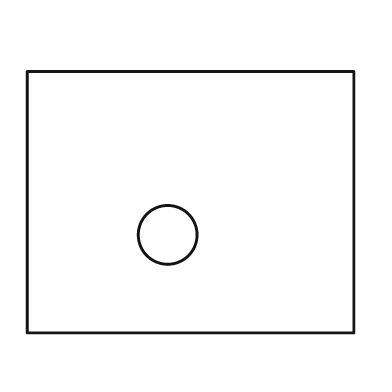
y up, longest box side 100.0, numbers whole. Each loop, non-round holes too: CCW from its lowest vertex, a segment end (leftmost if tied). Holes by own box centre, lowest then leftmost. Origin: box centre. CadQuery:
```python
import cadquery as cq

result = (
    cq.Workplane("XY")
    .moveTo(-50.0, -40.0)
    .lineTo(50.0, -40.0)
    .lineTo(50.0, 40.0)
    .lineTo(-50.0, 40.0)
    .close()
    .moveTo(-7.0, -10.0)
    .circle(9.0)
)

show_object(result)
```